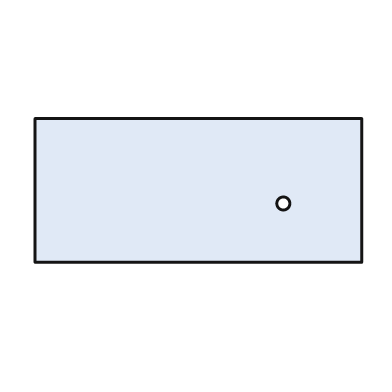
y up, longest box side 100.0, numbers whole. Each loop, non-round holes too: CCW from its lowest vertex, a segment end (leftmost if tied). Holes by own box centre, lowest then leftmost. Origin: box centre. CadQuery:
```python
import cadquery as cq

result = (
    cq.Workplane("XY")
    .moveTo(-50.0, -22.0)
    .lineTo(50.0, -22.0)
    .lineTo(50.0, 22.0)
    .lineTo(-50.0, 22.0)
    .close()
    .moveTo(26.0, -4.0)
    .circle(2.0)
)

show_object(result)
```